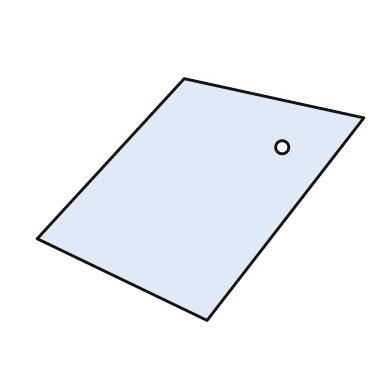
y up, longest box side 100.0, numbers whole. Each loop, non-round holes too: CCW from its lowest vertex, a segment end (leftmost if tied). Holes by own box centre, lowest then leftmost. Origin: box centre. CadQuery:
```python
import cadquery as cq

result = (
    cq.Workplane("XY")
    .moveTo(2.0, -37.0)
    .lineTo(50.0, 25.0)
    .lineTo(-5.0, 37.0)
    .lineTo(-50.0, -12.0)
    .close()
    .moveTo(25.0, 16.0)
    .circle(2.0)
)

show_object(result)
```